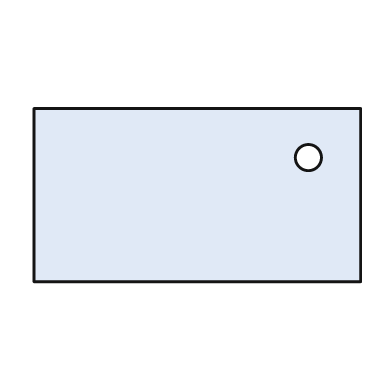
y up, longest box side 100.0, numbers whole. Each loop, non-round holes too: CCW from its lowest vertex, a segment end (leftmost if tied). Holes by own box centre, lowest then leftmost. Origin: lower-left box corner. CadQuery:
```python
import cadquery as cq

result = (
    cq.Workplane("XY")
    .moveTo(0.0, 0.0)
    .lineTo(100.0, 0.0)
    .lineTo(100.0, 53.0)
    .lineTo(0.0, 53.0)
    .close()
    .moveTo(84.0, 38.0)
    .circle(4.0)
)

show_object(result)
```